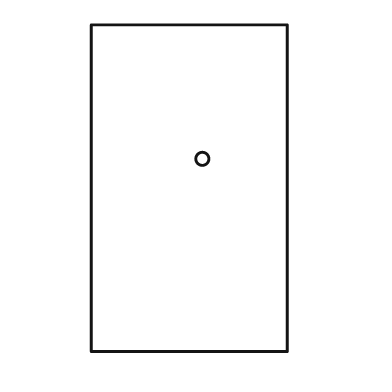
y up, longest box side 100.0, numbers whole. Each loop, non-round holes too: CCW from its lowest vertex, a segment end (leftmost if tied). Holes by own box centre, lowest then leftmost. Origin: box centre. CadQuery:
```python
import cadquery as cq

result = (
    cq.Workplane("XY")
    .moveTo(-30.0, -50.0)
    .lineTo(30.0, -50.0)
    .lineTo(30.0, 50.0)
    .lineTo(-30.0, 50.0)
    .close()
    .moveTo(4.0, 9.0)
    .circle(2.0)
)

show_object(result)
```